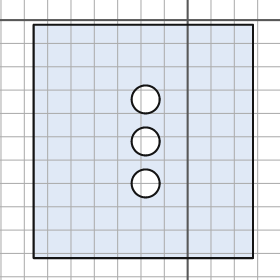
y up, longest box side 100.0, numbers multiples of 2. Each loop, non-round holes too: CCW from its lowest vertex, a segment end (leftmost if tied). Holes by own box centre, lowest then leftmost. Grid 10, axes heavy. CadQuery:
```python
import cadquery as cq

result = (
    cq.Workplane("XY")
    .moveTo(-66.0, -102.0)
    .lineTo(28.0, -102.0)
    .lineTo(28.0, -2.0)
    .lineTo(-66.0, -2.0)
    .close()
    .moveTo(-18.0, -70.0)
    .circle(6.0)
    .moveTo(-18.0, -52.0)
    .circle(6.0)
    .moveTo(-18.0, -34.0)
    .circle(6.0)
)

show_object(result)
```